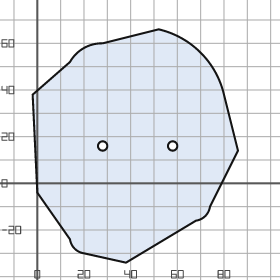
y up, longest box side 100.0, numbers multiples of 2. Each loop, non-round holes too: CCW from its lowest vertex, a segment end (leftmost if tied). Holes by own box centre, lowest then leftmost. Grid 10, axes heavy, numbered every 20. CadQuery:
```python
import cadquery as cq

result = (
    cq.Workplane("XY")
    .moveTo(38.0, -34.0)
    .lineTo(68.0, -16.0)
    .threePointArc((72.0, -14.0), (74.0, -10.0))
    .lineTo(86.0, 14.0)
    .lineTo(80.0, 38.0)
    .threePointArc((70.0, 56.0), (52.0, 66.0))
    .lineTo(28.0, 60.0)
    .threePointArc((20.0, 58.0), (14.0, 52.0))
    .lineTo(-2.0, 38.0)
    .lineTo(0.0, -4.0)
    .lineTo(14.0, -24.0)
    .threePointArc((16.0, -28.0), (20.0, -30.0))
    .close()
    .moveTo(28.0, 16.0)
    .circle(2.0)
    .moveTo(58.0, 16.0)
    .circle(2.0)
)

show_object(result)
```